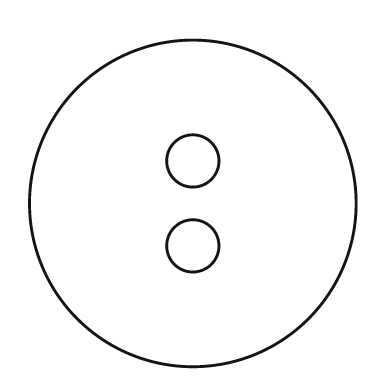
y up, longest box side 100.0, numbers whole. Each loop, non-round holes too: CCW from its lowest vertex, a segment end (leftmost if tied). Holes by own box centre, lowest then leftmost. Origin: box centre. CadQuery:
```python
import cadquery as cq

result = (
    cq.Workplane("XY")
    .moveTo(0.0, 0.0)
    .circle(50.0)
    .moveTo(0.0, -13.0)
    .circle(8.0)
    .moveTo(0.0, 13.0)
    .circle(8.0)
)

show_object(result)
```